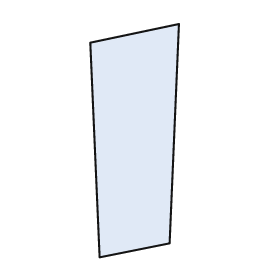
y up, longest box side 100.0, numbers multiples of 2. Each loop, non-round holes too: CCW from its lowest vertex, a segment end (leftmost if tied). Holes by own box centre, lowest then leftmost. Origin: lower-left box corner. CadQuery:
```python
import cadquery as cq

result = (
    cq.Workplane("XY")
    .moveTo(4.0, 0.0)
    .lineTo(34.0, 6.0)
    .lineTo(38.0, 100.0)
    .lineTo(0.0, 92.0)
    .close()
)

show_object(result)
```